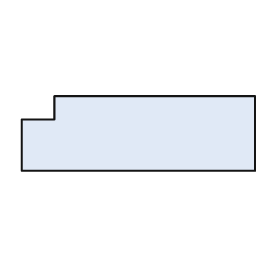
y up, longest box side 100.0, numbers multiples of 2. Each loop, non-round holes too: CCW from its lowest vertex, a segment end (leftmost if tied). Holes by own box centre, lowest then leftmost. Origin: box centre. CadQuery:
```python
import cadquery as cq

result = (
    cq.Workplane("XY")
    .moveTo(-50.0, -16.0)
    .lineTo(50.0, -16.0)
    .lineTo(50.0, 16.0)
    .lineTo(-36.0, 16.0)
    .lineTo(-36.0, 6.0)
    .lineTo(-50.0, 6.0)
    .close()
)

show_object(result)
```